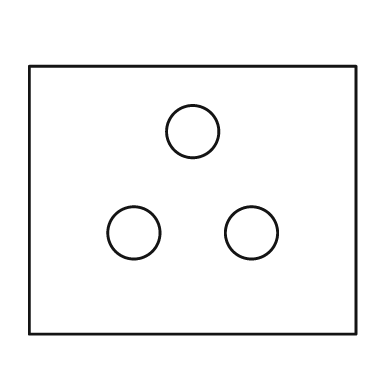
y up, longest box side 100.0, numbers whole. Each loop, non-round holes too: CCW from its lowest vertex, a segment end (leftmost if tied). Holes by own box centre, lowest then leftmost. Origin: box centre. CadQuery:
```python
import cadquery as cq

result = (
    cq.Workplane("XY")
    .moveTo(-50.0, -41.0)
    .lineTo(50.0, -41.0)
    .lineTo(50.0, 41.0)
    .lineTo(-50.0, 41.0)
    .close()
    .moveTo(-18.0, -10.0)
    .circle(8.0)
    .moveTo(18.0, -10.0)
    .circle(8.0)
    .moveTo(0.0, 21.0)
    .circle(8.0)
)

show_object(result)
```